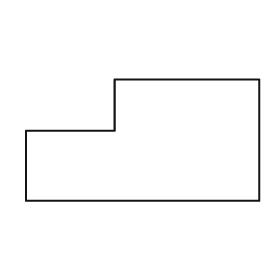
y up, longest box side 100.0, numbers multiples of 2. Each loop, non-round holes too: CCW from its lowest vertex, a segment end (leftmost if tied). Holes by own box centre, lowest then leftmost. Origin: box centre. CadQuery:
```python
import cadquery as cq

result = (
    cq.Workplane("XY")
    .moveTo(-50.0, -26.0)
    .lineTo(50.0, -26.0)
    .lineTo(50.0, 26.0)
    .lineTo(-12.0, 26.0)
    .lineTo(-12.0, 4.0)
    .lineTo(-50.0, 4.0)
    .close()
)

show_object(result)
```